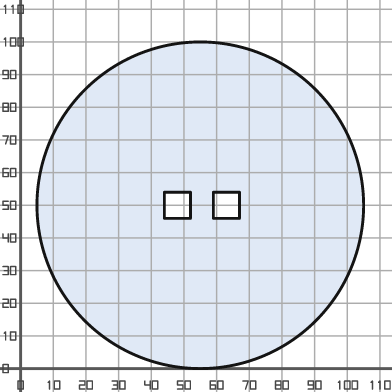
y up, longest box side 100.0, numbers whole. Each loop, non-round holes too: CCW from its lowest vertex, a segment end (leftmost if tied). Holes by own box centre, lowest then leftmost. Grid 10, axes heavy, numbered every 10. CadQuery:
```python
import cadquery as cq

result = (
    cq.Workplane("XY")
    .moveTo(55.0, 50.0)
    .circle(50.0)
    .moveTo(44.0, 46.0)
    .lineTo(52.0, 46.0)
    .lineTo(52.0, 54.0)
    .lineTo(44.0, 54.0)
    .close()
    .moveTo(59.0, 46.0)
    .lineTo(67.0, 46.0)
    .lineTo(67.0, 54.0)
    .lineTo(59.0, 54.0)
    .close()
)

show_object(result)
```